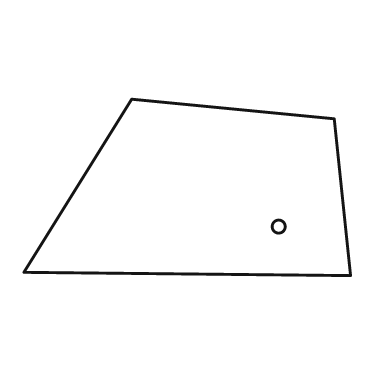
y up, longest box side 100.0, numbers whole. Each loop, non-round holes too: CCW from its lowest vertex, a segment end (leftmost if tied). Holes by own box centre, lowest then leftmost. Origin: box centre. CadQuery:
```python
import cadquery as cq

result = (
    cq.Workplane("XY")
    .moveTo(50.0, -27.0)
    .lineTo(45.0, 21.0)
    .lineTo(-17.0, 27.0)
    .lineTo(-50.0, -26.0)
    .close()
    .moveTo(28.0, -12.0)
    .circle(2.0)
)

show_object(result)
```